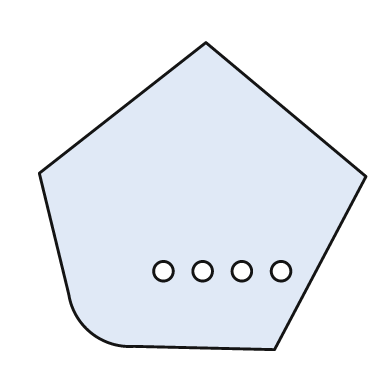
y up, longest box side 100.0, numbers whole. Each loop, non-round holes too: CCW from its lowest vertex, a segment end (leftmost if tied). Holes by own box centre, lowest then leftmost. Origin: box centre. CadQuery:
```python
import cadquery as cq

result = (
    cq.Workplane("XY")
    .moveTo(22.0, -47.0)
    .lineTo(50.0, 6.0)
    .lineTo(1.0, 47.0)
    .lineTo(-50.0, 7.0)
    .lineTo(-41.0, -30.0)
    .threePointArc((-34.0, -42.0), (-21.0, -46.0))
    .close()
    .moveTo(-12.0, -23.0)
    .circle(3.0)
    .moveTo(0.0, -23.0)
    .circle(3.0)
    .moveTo(12.0, -23.0)
    .circle(3.0)
    .moveTo(24.0, -23.0)
    .circle(3.0)
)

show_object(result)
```